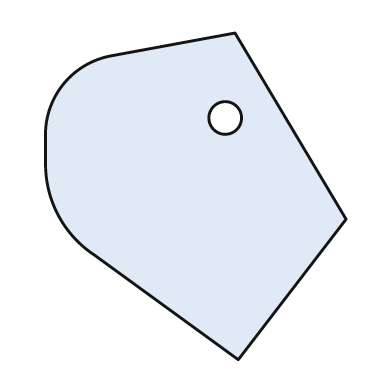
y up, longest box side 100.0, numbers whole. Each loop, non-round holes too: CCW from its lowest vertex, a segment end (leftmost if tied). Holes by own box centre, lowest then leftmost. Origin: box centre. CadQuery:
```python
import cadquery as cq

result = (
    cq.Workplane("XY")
    .moveTo(13.0, -50.0)
    .lineTo(46.0, -7.0)
    .lineTo(12.0, 50.0)
    .lineTo(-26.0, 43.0)
    .threePointArc((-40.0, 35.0), (-46.0, 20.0))
    .lineTo(-46.0, 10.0)
    .threePointArc((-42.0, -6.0), (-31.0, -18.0))
    .close()
    .moveTo(9.0, 24.0)
    .circle(5.0)
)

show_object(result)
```